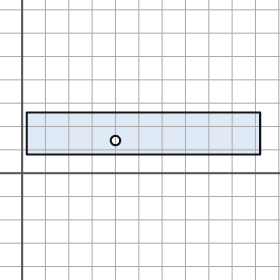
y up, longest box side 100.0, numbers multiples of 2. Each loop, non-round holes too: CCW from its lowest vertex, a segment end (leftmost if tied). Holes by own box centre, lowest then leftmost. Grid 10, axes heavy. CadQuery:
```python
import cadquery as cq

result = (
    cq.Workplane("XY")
    .moveTo(2.0, 8.0)
    .lineTo(102.0, 8.0)
    .lineTo(102.0, 26.0)
    .lineTo(2.0, 26.0)
    .close()
    .moveTo(40.0, 14.0)
    .circle(2.0)
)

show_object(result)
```